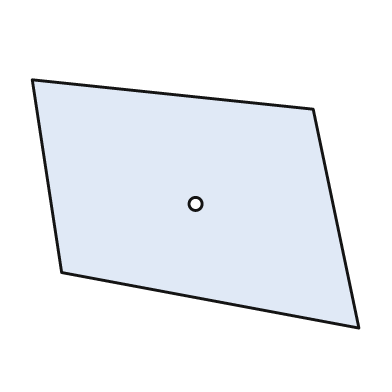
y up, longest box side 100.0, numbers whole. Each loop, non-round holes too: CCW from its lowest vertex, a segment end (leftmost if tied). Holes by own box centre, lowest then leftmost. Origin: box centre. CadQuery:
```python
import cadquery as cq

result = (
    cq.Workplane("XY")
    .moveTo(50.0, -38.0)
    .lineTo(36.0, 29.0)
    .lineTo(-50.0, 38.0)
    .lineTo(-41.0, -21.0)
    .close()
    .moveTo(0.0, 0.0)
    .circle(2.0)
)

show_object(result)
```